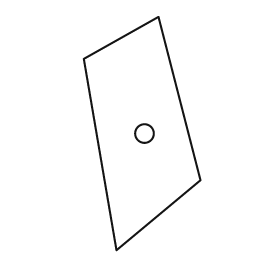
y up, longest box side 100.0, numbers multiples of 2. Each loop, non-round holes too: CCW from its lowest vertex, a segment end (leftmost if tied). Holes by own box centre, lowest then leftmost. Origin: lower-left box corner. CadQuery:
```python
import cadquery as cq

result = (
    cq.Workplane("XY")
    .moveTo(14.0, 0.0)
    .lineTo(50.0, 30.0)
    .lineTo(32.0, 100.0)
    .lineTo(0.0, 82.0)
    .close()
    .moveTo(26.0, 50.0)
    .circle(4.0)
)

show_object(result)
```